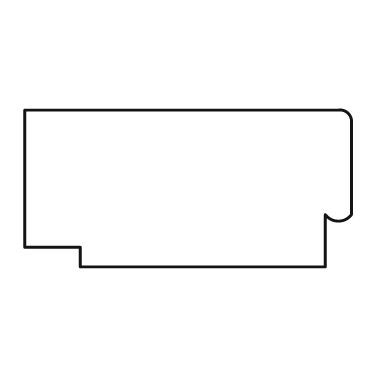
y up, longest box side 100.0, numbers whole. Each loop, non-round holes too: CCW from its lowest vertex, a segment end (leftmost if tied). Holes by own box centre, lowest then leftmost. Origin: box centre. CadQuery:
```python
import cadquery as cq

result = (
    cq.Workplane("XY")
    .moveTo(-33.0, -24.0)
    .lineTo(42.0, -24.0)
    .lineTo(42.0, -8.0)
    .threePointArc((46.0, -10.0), (50.0, -8.0))
    .lineTo(50.0, 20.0)
    .threePointArc((49.0, 23.0), (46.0, 24.0))
    .lineTo(-50.0, 24.0)
    .lineTo(-50.0, -18.0)
    .lineTo(-33.0, -18.0)
    .close()
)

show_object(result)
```